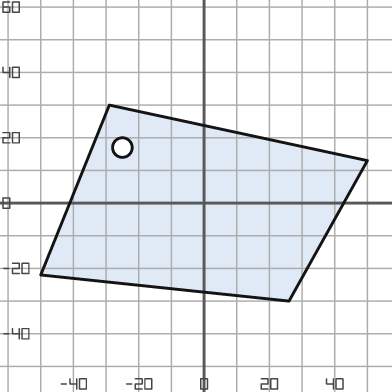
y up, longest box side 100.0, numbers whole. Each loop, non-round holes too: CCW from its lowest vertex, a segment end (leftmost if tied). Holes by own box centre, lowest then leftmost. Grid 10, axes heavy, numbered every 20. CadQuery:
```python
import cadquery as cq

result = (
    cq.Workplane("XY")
    .moveTo(26.0, -30.0)
    .lineTo(50.0, 13.0)
    .lineTo(-29.0, 30.0)
    .lineTo(-50.0, -22.0)
    .close()
    .moveTo(-25.0, 17.0)
    .circle(3.0)
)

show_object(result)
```